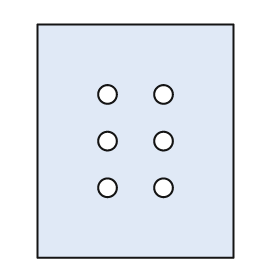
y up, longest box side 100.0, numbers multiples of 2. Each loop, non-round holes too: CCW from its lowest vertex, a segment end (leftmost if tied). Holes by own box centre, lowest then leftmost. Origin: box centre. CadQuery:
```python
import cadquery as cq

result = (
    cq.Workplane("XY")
    .moveTo(-42.0, -50.0)
    .lineTo(42.0, -50.0)
    .lineTo(42.0, 50.0)
    .lineTo(-42.0, 50.0)
    .close()
    .moveTo(-12.0, -20.0)
    .circle(4.0)
    .moveTo(12.0, -20.0)
    .circle(4.0)
    .moveTo(-12.0, 0.0)
    .circle(4.0)
    .moveTo(12.0, 0.0)
    .circle(4.0)
    .moveTo(-12.0, 20.0)
    .circle(4.0)
    .moveTo(12.0, 20.0)
    .circle(4.0)
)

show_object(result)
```